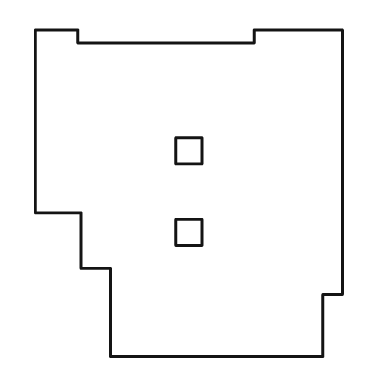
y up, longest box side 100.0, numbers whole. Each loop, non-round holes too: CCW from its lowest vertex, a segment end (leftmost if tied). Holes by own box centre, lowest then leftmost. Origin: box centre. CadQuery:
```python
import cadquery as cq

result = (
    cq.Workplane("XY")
    .moveTo(-24.0, -50.0)
    .lineTo(41.0, -50.0)
    .lineTo(41.0, -31.0)
    .lineTo(47.0, -31.0)
    .lineTo(47.0, 50.0)
    .lineTo(20.0, 50.0)
    .lineTo(20.0, 46.0)
    .lineTo(-34.0, 46.0)
    .lineTo(-34.0, 50.0)
    .lineTo(-47.0, 50.0)
    .lineTo(-47.0, -6.0)
    .lineTo(-33.0, -6.0)
    .lineTo(-33.0, -23.0)
    .lineTo(-24.0, -23.0)
    .close()
    .moveTo(-4.0, -16.0)
    .lineTo(4.0, -16.0)
    .lineTo(4.0, -8.0)
    .lineTo(-4.0, -8.0)
    .close()
    .moveTo(-4.0, 9.0)
    .lineTo(4.0, 9.0)
    .lineTo(4.0, 17.0)
    .lineTo(-4.0, 17.0)
    .close()
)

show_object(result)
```